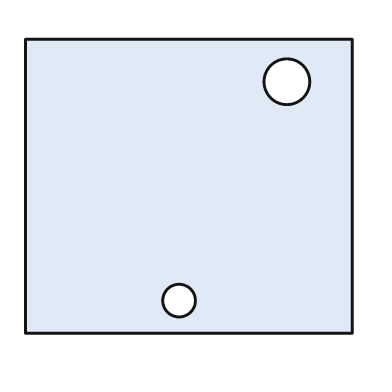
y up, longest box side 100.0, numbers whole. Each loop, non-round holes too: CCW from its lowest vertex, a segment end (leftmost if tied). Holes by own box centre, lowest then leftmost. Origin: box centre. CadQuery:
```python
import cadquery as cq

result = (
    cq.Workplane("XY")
    .moveTo(-50.0, -45.0)
    .lineTo(50.0, -45.0)
    .lineTo(50.0, 45.0)
    .lineTo(-50.0, 45.0)
    .close()
    .moveTo(-3.0, -35.0)
    .circle(5.0)
    .moveTo(30.0, 32.0)
    .circle(7.0)
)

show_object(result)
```